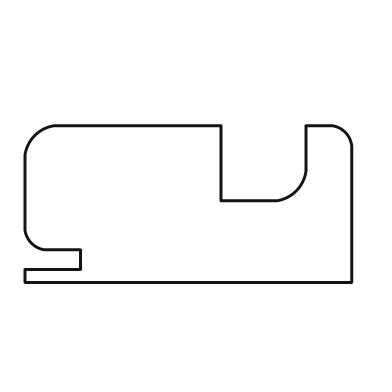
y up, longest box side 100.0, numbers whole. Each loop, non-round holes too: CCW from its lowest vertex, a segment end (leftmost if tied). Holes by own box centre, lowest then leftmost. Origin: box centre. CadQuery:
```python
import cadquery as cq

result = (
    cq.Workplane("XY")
    .moveTo(-50.0, -24.0)
    .lineTo(50.0, -24.0)
    .lineTo(50.0, 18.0)
    .threePointArc((48.0, 22.0), (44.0, 24.0))
    .lineTo(36.0, 24.0)
    .lineTo(36.0, 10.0)
    .threePointArc((33.0, 4.0), (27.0, 1.0))
    .lineTo(10.0, 1.0)
    .lineTo(10.0, 24.0)
    .lineTo(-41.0, 24.0)
    .threePointArc((-47.0, 21.0), (-50.0, 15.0))
    .lineTo(-50.0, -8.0)
    .threePointArc((-48.0, -12.0), (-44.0, -14.0))
    .lineTo(-33.0, -14.0)
    .lineTo(-33.0, -20.0)
    .lineTo(-50.0, -20.0)
    .close()
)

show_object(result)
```